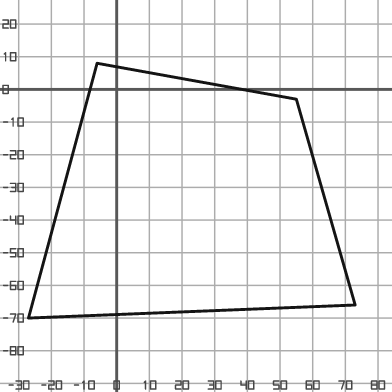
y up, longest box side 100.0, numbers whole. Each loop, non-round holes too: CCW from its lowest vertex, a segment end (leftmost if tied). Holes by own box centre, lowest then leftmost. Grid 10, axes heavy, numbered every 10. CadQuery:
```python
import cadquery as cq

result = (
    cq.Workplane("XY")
    .moveTo(-27.0, -70.0)
    .lineTo(73.0, -66.0)
    .lineTo(55.0, -3.0)
    .lineTo(-6.0, 8.0)
    .close()
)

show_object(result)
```